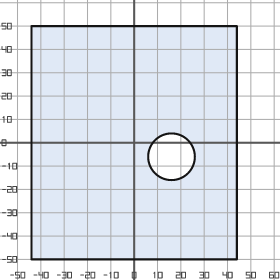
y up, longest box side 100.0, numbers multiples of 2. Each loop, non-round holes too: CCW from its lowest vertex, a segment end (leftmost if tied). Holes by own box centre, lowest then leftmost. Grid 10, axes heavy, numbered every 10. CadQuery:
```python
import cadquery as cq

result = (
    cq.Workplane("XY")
    .moveTo(-44.0, -50.0)
    .lineTo(44.0, -50.0)
    .lineTo(44.0, 50.0)
    .lineTo(-44.0, 50.0)
    .close()
    .moveTo(16.0, -6.0)
    .circle(10.0)
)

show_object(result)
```